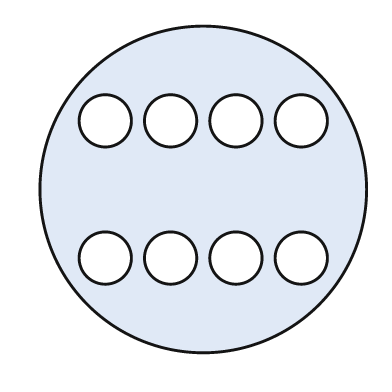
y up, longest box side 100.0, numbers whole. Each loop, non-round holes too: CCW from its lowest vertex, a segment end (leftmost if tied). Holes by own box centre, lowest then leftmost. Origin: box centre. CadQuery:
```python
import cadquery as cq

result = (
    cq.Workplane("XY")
    .moveTo(0.0, 0.0)
    .circle(50.0)
    .moveTo(-30.0, -21.0)
    .circle(8.0)
    .moveTo(-10.0, -21.0)
    .circle(8.0)
    .moveTo(10.0, -21.0)
    .circle(8.0)
    .moveTo(30.0, -21.0)
    .circle(8.0)
    .moveTo(-30.0, 21.0)
    .circle(8.0)
    .moveTo(-10.0, 21.0)
    .circle(8.0)
    .moveTo(10.0, 21.0)
    .circle(8.0)
    .moveTo(30.0, 21.0)
    .circle(8.0)
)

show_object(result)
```